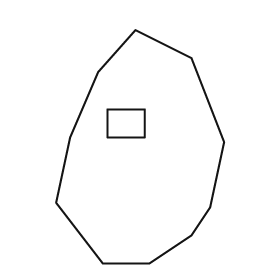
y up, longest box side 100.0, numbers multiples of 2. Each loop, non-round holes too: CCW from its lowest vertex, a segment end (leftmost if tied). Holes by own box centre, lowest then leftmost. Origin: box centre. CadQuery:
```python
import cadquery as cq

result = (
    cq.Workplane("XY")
    .moveTo(-16.0, -50.0)
    .lineTo(4.0, -50.0)
    .lineTo(22.0, -38.0)
    .lineTo(30.0, -26.0)
    .lineTo(36.0, 2.0)
    .lineTo(22.0, 38.0)
    .lineTo(-2.0, 50.0)
    .lineTo(-18.0, 32.0)
    .lineTo(-30.0, 4.0)
    .lineTo(-36.0, -24.0)
    .close()
    .moveTo(-14.0, 4.0)
    .lineTo(2.0, 4.0)
    .lineTo(2.0, 16.0)
    .lineTo(-14.0, 16.0)
    .close()
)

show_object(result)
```